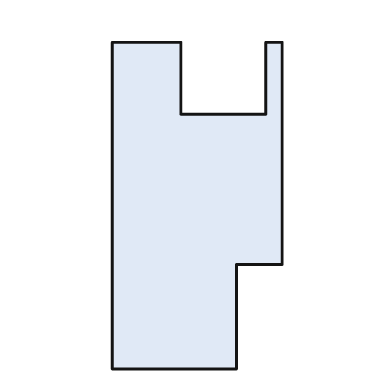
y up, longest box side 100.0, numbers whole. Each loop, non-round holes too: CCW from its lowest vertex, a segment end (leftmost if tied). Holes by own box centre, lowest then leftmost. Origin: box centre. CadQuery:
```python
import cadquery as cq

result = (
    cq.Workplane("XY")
    .moveTo(-26.0, -50.0)
    .lineTo(12.0, -50.0)
    .lineTo(12.0, -18.0)
    .lineTo(26.0, -18.0)
    .lineTo(26.0, 50.0)
    .lineTo(21.0, 50.0)
    .lineTo(21.0, 28.0)
    .lineTo(-5.0, 28.0)
    .lineTo(-5.0, 50.0)
    .lineTo(-26.0, 50.0)
    .close()
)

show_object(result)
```